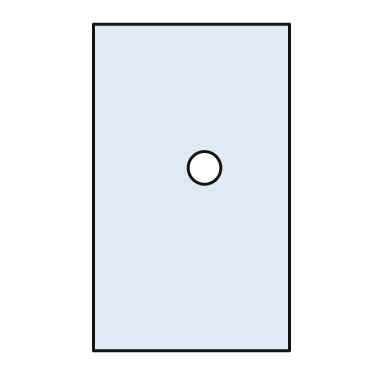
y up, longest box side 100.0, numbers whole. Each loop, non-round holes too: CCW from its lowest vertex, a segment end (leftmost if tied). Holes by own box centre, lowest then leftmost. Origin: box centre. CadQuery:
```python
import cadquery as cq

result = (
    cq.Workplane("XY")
    .moveTo(-30.0, -50.0)
    .lineTo(30.0, -50.0)
    .lineTo(30.0, 50.0)
    .lineTo(-30.0, 50.0)
    .close()
    .moveTo(4.0, 6.0)
    .circle(5.0)
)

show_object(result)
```